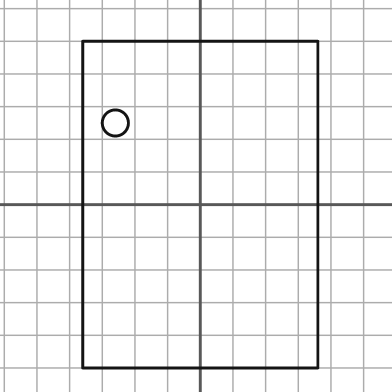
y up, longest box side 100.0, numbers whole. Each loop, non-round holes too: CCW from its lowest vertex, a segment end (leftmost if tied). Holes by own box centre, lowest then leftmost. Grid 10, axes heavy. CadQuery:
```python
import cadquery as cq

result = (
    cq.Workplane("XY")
    .moveTo(-36.0, -50.0)
    .lineTo(36.0, -50.0)
    .lineTo(36.0, 50.0)
    .lineTo(-36.0, 50.0)
    .close()
    .moveTo(-26.0, 25.0)
    .circle(4.0)
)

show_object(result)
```